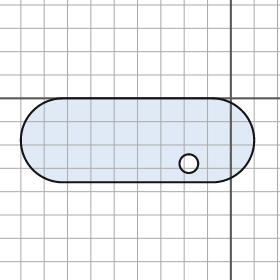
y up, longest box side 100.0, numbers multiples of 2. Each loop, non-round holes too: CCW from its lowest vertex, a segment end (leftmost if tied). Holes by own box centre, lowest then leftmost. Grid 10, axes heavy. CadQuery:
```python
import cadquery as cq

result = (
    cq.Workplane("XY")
    .moveTo(-72.0, -36.0)
    .lineTo(-8.0, -36.0)
    .threePointArc((10.0, -18.0), (-8.0, 0.0))
    .lineTo(-72.0, 0.0)
    .threePointArc((-90.0, -18.0), (-72.0, -36.0))
    .close()
    .moveTo(-18.0, -28.0)
    .circle(4.0)
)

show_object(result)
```